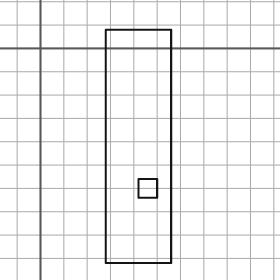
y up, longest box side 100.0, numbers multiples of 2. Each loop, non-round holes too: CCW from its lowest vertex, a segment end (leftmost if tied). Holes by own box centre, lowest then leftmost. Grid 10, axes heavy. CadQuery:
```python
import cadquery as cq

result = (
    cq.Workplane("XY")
    .moveTo(28.0, -92.0)
    .lineTo(56.0, -92.0)
    .lineTo(56.0, 8.0)
    .lineTo(28.0, 8.0)
    .close()
    .moveTo(42.0, -64.0)
    .lineTo(50.0, -64.0)
    .lineTo(50.0, -56.0)
    .lineTo(42.0, -56.0)
    .close()
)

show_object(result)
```